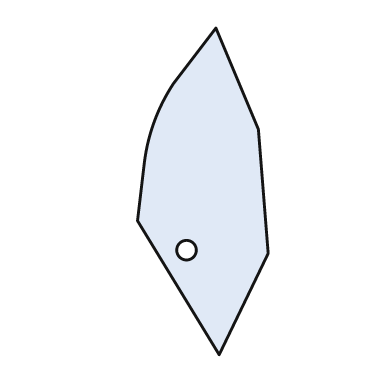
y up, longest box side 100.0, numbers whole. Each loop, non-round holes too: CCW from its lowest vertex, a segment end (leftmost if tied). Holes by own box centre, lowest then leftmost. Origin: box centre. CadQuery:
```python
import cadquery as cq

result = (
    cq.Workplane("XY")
    .moveTo(5.0, -50.0)
    .lineTo(20.0, -19.0)
    .lineTo(17.0, 19.0)
    .lineTo(4.0, 50.0)
    .lineTo(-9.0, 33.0)
    .threePointArc((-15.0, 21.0), (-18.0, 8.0))
    .lineTo(-20.0, -9.0)
    .close()
    .moveTo(-5.0, -18.0)
    .circle(3.0)
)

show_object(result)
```